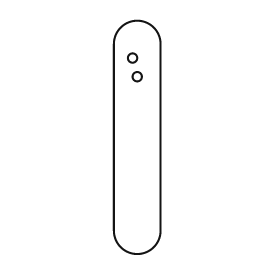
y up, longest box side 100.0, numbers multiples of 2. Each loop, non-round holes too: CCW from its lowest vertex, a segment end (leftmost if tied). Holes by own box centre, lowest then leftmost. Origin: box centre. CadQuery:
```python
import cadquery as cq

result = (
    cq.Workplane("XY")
    .moveTo(-10.0, -40.0)
    .threePointArc((0.0, -50.0), (10.0, -40.0))
    .lineTo(10.0, 40.0)
    .threePointArc((0.0, 50.0), (-10.0, 40.0))
    .close()
    .moveTo(0.0, 26.0)
    .circle(2.0)
    .moveTo(-2.0, 34.0)
    .circle(2.0)
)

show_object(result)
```